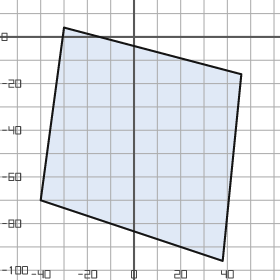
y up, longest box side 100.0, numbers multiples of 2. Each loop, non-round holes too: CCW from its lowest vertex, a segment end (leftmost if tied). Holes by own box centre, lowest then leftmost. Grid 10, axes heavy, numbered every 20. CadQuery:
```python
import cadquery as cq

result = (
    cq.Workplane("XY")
    .moveTo(38.0, -96.0)
    .lineTo(46.0, -16.0)
    .lineTo(-30.0, 4.0)
    .lineTo(-40.0, -70.0)
    .close()
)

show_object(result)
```